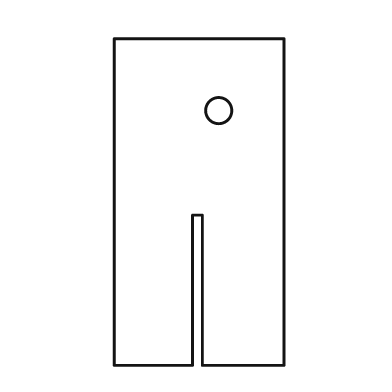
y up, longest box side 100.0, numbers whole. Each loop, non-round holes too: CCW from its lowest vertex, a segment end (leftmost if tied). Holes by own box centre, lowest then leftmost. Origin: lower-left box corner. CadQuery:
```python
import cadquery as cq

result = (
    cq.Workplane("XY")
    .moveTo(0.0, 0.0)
    .lineTo(24.0, 0.0)
    .lineTo(24.0, 46.0)
    .lineTo(27.0, 46.0)
    .lineTo(27.0, 0.0)
    .lineTo(52.0, 0.0)
    .lineTo(52.0, 100.0)
    .lineTo(0.0, 100.0)
    .close()
    .moveTo(32.0, 78.0)
    .circle(4.0)
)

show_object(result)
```